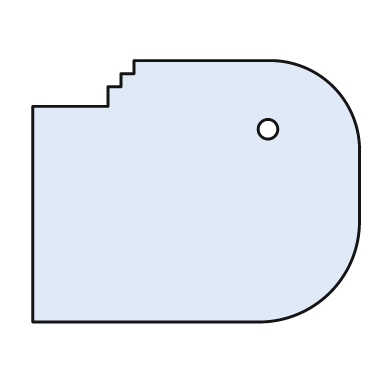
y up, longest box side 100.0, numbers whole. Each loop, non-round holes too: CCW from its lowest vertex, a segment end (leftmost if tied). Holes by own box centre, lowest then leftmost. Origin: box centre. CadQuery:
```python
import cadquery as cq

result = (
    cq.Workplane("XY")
    .moveTo(-50.0, -40.0)
    .lineTo(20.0, -40.0)
    .threePointArc((41.0, -31.0), (50.0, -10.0))
    .lineTo(50.0, 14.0)
    .threePointArc((42.0, 32.0), (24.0, 40.0))
    .lineTo(-19.0, 40.0)
    .lineTo(-19.0, 36.0)
    .lineTo(-23.0, 36.0)
    .lineTo(-23.0, 32.0)
    .lineTo(-27.0, 32.0)
    .lineTo(-27.0, 26.0)
    .lineTo(-50.0, 26.0)
    .close()
    .moveTo(22.0, 19.0)
    .circle(3.0)
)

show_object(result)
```